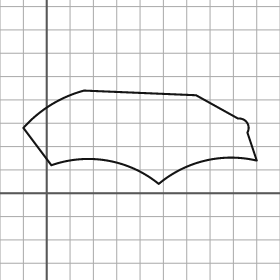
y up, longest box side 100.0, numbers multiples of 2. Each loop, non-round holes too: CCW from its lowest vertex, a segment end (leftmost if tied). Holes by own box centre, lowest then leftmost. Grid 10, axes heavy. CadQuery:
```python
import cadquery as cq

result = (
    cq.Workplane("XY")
    .moveTo(48.0, 4.0)
    .threePointArc((68.0, 14.0), (90.0, 14.0))
    .lineTo(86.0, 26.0)
    .threePointArc((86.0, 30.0), (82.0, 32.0))
    .lineTo(64.0, 42.0)
    .lineTo(16.0, 44.0)
    .threePointArc((2.0, 38.0), (-10.0, 28.0))
    .lineTo(2.0, 12.0)
    .threePointArc((26.0, 14.0), (48.0, 4.0))
    .close()
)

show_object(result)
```